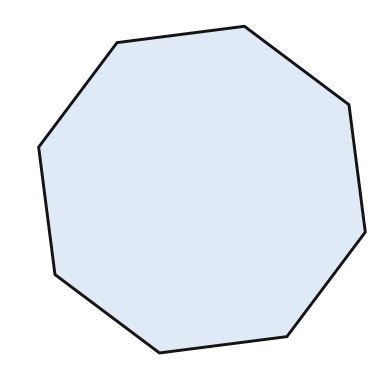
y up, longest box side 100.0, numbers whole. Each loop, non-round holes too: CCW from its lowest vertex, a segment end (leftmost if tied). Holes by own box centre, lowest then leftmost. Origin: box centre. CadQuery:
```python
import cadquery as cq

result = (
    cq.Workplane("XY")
    .moveTo(-13.0, -50.0)
    .lineTo(26.0, -45.0)
    .lineTo(50.0, -13.0)
    .lineTo(45.0, 26.0)
    .lineTo(13.0, 50.0)
    .lineTo(-26.0, 45.0)
    .lineTo(-50.0, 13.0)
    .lineTo(-45.0, -26.0)
    .close()
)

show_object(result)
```